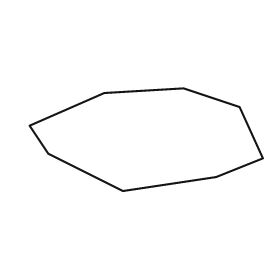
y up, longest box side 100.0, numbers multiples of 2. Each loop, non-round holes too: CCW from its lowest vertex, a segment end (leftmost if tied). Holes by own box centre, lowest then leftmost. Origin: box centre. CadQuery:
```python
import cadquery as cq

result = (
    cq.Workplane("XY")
    .moveTo(-10.0, -22.0)
    .lineTo(30.0, -16.0)
    .lineTo(50.0, -8.0)
    .lineTo(40.0, 14.0)
    .lineTo(16.0, 22.0)
    .lineTo(-18.0, 20.0)
    .lineTo(-50.0, 6.0)
    .lineTo(-42.0, -6.0)
    .close()
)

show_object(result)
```